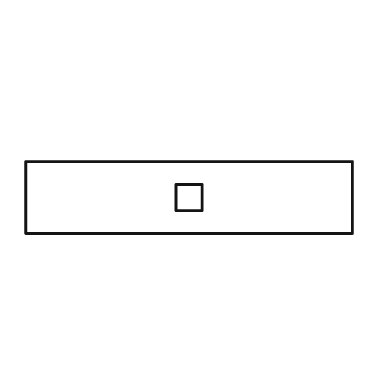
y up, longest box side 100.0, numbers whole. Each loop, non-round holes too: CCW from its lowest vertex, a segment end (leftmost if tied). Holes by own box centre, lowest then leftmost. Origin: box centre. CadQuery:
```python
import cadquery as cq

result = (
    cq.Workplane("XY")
    .moveTo(-50.0, -11.0)
    .lineTo(50.0, -11.0)
    .lineTo(50.0, 11.0)
    .lineTo(-50.0, 11.0)
    .close()
    .moveTo(-4.0, -4.0)
    .lineTo(4.0, -4.0)
    .lineTo(4.0, 4.0)
    .lineTo(-4.0, 4.0)
    .close()
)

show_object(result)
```